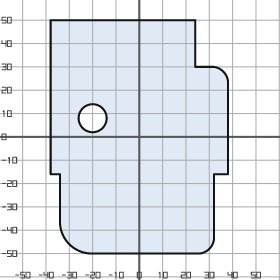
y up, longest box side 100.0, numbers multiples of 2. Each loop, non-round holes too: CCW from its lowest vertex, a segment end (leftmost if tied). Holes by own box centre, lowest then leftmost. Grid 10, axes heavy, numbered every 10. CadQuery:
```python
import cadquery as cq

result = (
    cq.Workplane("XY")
    .moveTo(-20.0, -50.0)
    .lineTo(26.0, -50.0)
    .threePointArc((30.0, -48.0), (32.0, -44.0))
    .lineTo(32.0, -16.0)
    .lineTo(38.0, -16.0)
    .lineTo(38.0, 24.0)
    .threePointArc((36.0, 28.0), (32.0, 30.0))
    .lineTo(24.0, 30.0)
    .lineTo(24.0, 50.0)
    .lineTo(-38.0, 50.0)
    .lineTo(-38.0, -16.0)
    .lineTo(-34.0, -16.0)
    .lineTo(-34.0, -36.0)
    .threePointArc((-30.0, -46.0), (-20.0, -50.0))
    .close()
    .moveTo(-20.0, 8.0)
    .circle(6.0)
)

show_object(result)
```